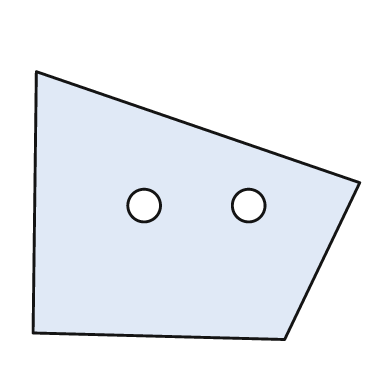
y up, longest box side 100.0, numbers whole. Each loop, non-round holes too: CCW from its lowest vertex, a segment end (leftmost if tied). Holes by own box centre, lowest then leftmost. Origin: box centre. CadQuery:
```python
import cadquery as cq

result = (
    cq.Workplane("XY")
    .moveTo(27.0, -41.0)
    .lineTo(50.0, 7.0)
    .lineTo(-49.0, 41.0)
    .lineTo(-50.0, -39.0)
    .close()
    .moveTo(-16.0, 0.0)
    .circle(5.0)
    .moveTo(16.0, 0.0)
    .circle(5.0)
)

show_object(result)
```